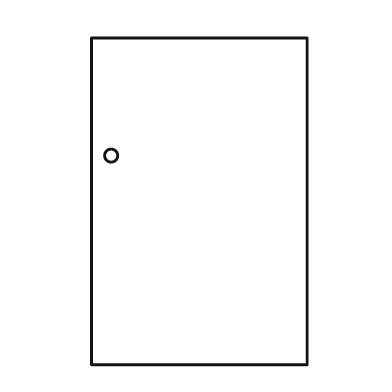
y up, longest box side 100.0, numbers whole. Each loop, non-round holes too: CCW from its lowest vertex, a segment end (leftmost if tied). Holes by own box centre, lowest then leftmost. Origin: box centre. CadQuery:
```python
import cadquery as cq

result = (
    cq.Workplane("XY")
    .moveTo(-33.0, -50.0)
    .lineTo(33.0, -50.0)
    .lineTo(33.0, 50.0)
    .lineTo(-33.0, 50.0)
    .close()
    .moveTo(-27.0, 14.0)
    .circle(2.0)
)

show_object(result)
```